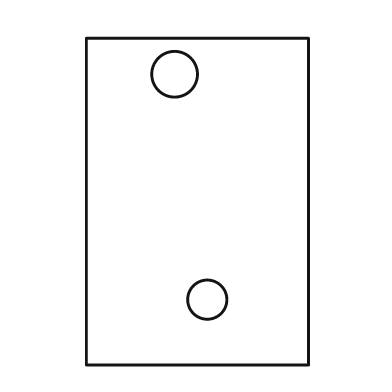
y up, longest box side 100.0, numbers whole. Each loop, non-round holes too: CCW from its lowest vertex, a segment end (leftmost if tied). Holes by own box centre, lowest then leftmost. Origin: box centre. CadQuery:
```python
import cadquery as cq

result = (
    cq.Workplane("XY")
    .moveTo(-34.0, -50.0)
    .lineTo(34.0, -50.0)
    .lineTo(34.0, 50.0)
    .lineTo(-34.0, 50.0)
    .close()
    .moveTo(3.0, -30.0)
    .circle(6.0)
    .moveTo(-7.0, 39.0)
    .circle(7.0)
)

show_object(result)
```